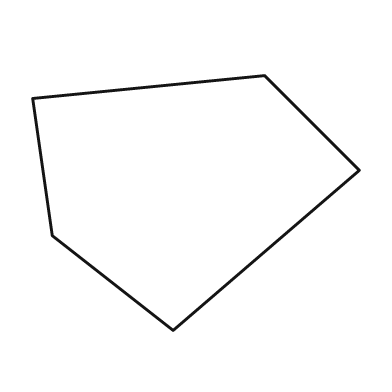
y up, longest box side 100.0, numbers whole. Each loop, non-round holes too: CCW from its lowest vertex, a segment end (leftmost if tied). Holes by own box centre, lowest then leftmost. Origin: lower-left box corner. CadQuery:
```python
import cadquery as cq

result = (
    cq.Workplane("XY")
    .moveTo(43.0, 0.0)
    .lineTo(100.0, 49.0)
    .lineTo(71.0, 78.0)
    .lineTo(0.0, 71.0)
    .lineTo(6.0, 29.0)
    .close()
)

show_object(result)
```